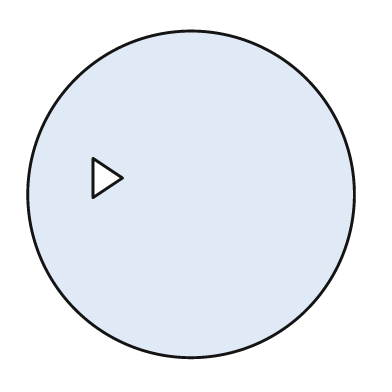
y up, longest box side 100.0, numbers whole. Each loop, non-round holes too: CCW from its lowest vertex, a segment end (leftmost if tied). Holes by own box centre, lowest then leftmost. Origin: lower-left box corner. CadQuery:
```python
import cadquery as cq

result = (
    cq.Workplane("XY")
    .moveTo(50.0, 50.0)
    .circle(50.0)
    .moveTo(20.0, 49.0)
    .lineTo(29.0, 55.0)
    .lineTo(20.0, 61.0)
    .close()
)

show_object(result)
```